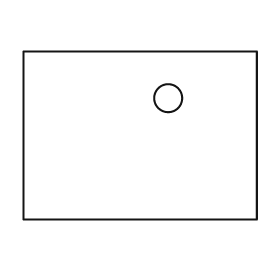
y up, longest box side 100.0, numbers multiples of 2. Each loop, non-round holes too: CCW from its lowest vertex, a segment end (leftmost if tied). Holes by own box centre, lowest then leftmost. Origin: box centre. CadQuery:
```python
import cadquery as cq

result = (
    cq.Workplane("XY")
    .moveTo(-50.0, -36.0)
    .lineTo(50.0, -36.0)
    .lineTo(50.0, 36.0)
    .lineTo(-50.0, 36.0)
    .close()
    .moveTo(12.0, 16.0)
    .circle(6.0)
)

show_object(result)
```